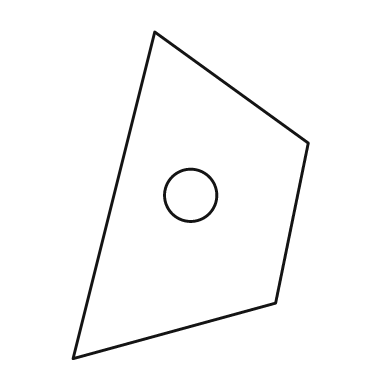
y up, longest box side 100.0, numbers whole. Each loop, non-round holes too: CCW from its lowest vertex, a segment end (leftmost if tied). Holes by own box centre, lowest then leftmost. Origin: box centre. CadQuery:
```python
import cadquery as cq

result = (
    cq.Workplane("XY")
    .moveTo(-36.0, -50.0)
    .lineTo(26.0, -33.0)
    .lineTo(36.0, 16.0)
    .lineTo(-11.0, 50.0)
    .close()
    .moveTo(0.0, 0.0)
    .circle(8.0)
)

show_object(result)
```